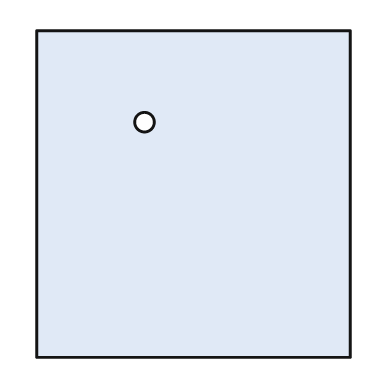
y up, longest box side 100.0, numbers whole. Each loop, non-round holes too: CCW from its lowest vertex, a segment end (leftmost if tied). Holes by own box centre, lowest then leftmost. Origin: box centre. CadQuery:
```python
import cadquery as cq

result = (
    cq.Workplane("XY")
    .moveTo(-48.0, -50.0)
    .lineTo(48.0, -50.0)
    .lineTo(48.0, 50.0)
    .lineTo(-48.0, 50.0)
    .close()
    .moveTo(-15.0, 22.0)
    .circle(3.0)
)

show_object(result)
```